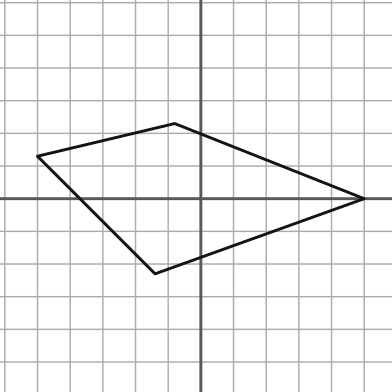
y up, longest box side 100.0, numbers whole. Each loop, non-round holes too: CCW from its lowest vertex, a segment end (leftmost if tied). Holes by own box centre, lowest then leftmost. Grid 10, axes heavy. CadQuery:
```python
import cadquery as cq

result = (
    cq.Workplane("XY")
    .moveTo(-14.0, -23.0)
    .lineTo(50.0, 0.0)
    .lineTo(-8.0, 23.0)
    .lineTo(-50.0, 13.0)
    .close()
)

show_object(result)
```